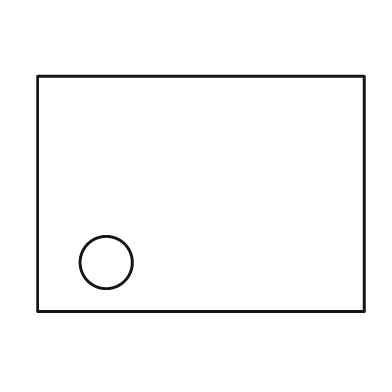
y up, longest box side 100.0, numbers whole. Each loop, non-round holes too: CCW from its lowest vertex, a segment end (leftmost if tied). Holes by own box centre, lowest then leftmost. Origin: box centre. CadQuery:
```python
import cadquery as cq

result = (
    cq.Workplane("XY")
    .moveTo(-50.0, -36.0)
    .lineTo(50.0, -36.0)
    .lineTo(50.0, 36.0)
    .lineTo(-50.0, 36.0)
    .close()
    .moveTo(-29.0, -21.0)
    .circle(8.0)
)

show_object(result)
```